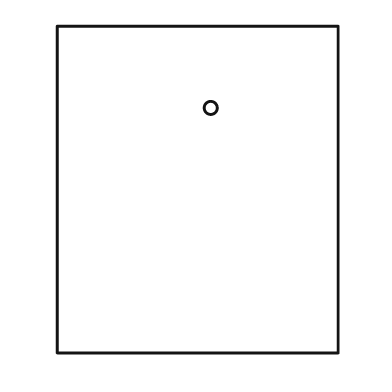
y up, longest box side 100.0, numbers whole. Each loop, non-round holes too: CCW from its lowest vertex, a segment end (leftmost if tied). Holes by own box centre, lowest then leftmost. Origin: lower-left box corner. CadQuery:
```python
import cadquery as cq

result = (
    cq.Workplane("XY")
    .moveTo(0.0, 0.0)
    .lineTo(86.0, 0.0)
    .lineTo(86.0, 100.0)
    .lineTo(0.0, 100.0)
    .close()
    .moveTo(47.0, 75.0)
    .circle(2.0)
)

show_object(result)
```